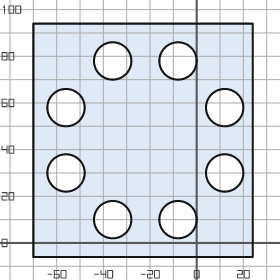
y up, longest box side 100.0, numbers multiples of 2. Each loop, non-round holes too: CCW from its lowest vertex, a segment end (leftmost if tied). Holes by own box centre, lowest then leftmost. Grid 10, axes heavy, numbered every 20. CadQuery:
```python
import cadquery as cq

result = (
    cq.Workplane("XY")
    .moveTo(-70.0, -6.0)
    .lineTo(24.0, -6.0)
    .lineTo(24.0, 94.0)
    .lineTo(-70.0, 94.0)
    .close()
    .moveTo(-36.0, 10.0)
    .circle(8.0)
    .moveTo(-8.0, 10.0)
    .circle(8.0)
    .moveTo(-56.0, 30.0)
    .circle(8.0)
    .moveTo(12.0, 30.0)
    .circle(8.0)
    .moveTo(-56.0, 58.0)
    .circle(8.0)
    .moveTo(12.0, 58.0)
    .circle(8.0)
    .moveTo(-36.0, 78.0)
    .circle(8.0)
    .moveTo(-8.0, 78.0)
    .circle(8.0)
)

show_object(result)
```